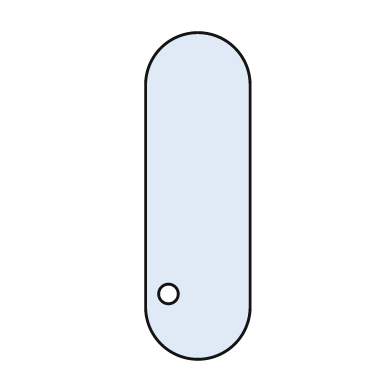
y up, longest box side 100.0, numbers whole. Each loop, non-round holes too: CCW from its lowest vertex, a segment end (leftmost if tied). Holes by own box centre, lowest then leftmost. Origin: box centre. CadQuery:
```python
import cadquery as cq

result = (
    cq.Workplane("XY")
    .moveTo(-16.0, -34.0)
    .threePointArc((0.0, -50.0), (16.0, -34.0))
    .lineTo(16.0, 34.0)
    .threePointArc((0.0, 50.0), (-16.0, 34.0))
    .close()
    .moveTo(-9.0, -30.0)
    .circle(3.0)
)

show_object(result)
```